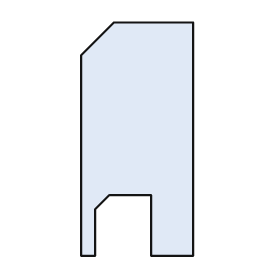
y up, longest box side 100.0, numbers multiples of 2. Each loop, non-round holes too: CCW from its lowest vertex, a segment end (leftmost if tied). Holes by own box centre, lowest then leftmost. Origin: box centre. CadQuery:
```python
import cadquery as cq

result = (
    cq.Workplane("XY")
    .moveTo(-24.0, -50.0)
    .lineTo(-18.0, -50.0)
    .lineTo(-18.0, -30.0)
    .lineTo(-12.0, -24.0)
    .lineTo(6.0, -24.0)
    .lineTo(6.0, -50.0)
    .lineTo(24.0, -50.0)
    .lineTo(24.0, 50.0)
    .lineTo(-10.0, 50.0)
    .lineTo(-24.0, 36.0)
    .close()
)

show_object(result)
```